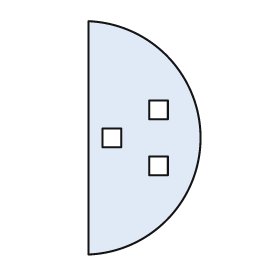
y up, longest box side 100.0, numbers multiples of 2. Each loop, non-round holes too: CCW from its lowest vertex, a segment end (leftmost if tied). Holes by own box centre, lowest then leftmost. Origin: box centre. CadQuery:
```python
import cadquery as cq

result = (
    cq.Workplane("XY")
    .moveTo(-24.0, -50.0)
    .threePointArc((24.0, 0.0), (-24.0, 50.0))
    .close()
    .moveTo(2.0, -16.0)
    .lineTo(10.0, -16.0)
    .lineTo(10.0, -8.0)
    .lineTo(2.0, -8.0)
    .close()
    .moveTo(-18.0, -4.0)
    .lineTo(-10.0, -4.0)
    .lineTo(-10.0, 4.0)
    .lineTo(-18.0, 4.0)
    .close()
    .moveTo(2.0, 8.0)
    .lineTo(10.0, 8.0)
    .lineTo(10.0, 16.0)
    .lineTo(2.0, 16.0)
    .close()
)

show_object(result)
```